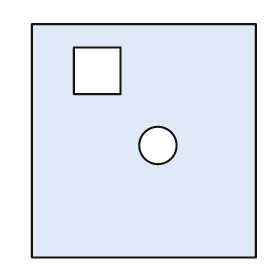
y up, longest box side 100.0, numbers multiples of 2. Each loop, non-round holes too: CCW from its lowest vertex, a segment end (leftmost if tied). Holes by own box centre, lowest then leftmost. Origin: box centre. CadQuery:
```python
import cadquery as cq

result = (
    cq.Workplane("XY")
    .moveTo(-48.0, -50.0)
    .lineTo(48.0, -50.0)
    .lineTo(48.0, 50.0)
    .lineTo(-48.0, 50.0)
    .close()
    .moveTo(6.0, -2.0)
    .circle(8.0)
    .moveTo(-30.0, 20.0)
    .lineTo(-10.0, 20.0)
    .lineTo(-10.0, 40.0)
    .lineTo(-30.0, 40.0)
    .close()
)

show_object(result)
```